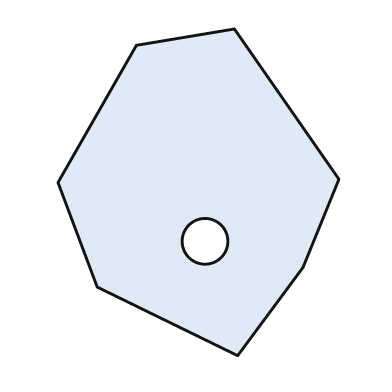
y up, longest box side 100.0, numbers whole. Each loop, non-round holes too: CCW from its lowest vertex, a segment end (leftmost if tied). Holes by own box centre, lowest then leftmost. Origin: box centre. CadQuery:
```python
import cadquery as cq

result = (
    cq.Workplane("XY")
    .moveTo(12.0, -50.0)
    .lineTo(32.0, -23.0)
    .lineTo(43.0, 4.0)
    .lineTo(11.0, 50.0)
    .lineTo(-19.0, 45.0)
    .lineTo(-43.0, 3.0)
    .lineTo(-31.0, -29.0)
    .close()
    .moveTo(2.0, -15.0)
    .circle(7.0)
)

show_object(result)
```